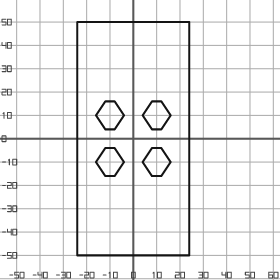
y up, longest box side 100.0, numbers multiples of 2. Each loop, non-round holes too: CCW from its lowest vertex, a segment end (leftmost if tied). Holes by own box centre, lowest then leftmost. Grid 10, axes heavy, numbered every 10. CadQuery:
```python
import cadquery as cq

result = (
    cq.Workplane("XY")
    .moveTo(-24.0, -50.0)
    .lineTo(24.0, -50.0)
    .lineTo(24.0, 50.0)
    .lineTo(-24.0, 50.0)
    .close()
    .moveTo(-12.0, -16.0)
    .lineTo(-8.0, -16.0)
    .lineTo(-4.0, -10.0)
    .lineTo(-8.0, -4.0)
    .lineTo(-12.0, -4.0)
    .lineTo(-16.0, -10.0)
    .close()
    .moveTo(8.0, -16.0)
    .lineTo(12.0, -16.0)
    .lineTo(16.0, -10.0)
    .lineTo(12.0, -4.0)
    .lineTo(8.0, -4.0)
    .lineTo(4.0, -10.0)
    .close()
    .moveTo(-12.0, 4.0)
    .lineTo(-8.0, 4.0)
    .lineTo(-4.0, 10.0)
    .lineTo(-8.0, 16.0)
    .lineTo(-12.0, 16.0)
    .lineTo(-16.0, 10.0)
    .close()
    .moveTo(8.0, 4.0)
    .lineTo(12.0, 4.0)
    .lineTo(16.0, 10.0)
    .lineTo(12.0, 16.0)
    .lineTo(8.0, 16.0)
    .lineTo(4.0, 10.0)
    .close()
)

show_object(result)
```